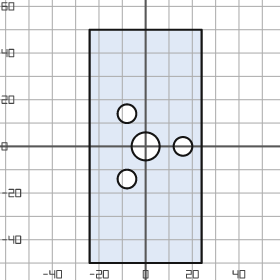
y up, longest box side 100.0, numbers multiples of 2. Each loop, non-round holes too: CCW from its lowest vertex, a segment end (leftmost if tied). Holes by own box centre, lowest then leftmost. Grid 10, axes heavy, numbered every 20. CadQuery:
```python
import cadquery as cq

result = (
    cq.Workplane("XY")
    .moveTo(-24.0, -50.0)
    .lineTo(24.0, -50.0)
    .lineTo(24.0, 50.0)
    .lineTo(-24.0, 50.0)
    .close()
    .moveTo(-8.0, -14.0)
    .circle(4.0)
    .moveTo(0.0, 0.0)
    .circle(6.0)
    .moveTo(16.0, 0.0)
    .circle(4.0)
    .moveTo(-8.0, 14.0)
    .circle(4.0)
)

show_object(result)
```